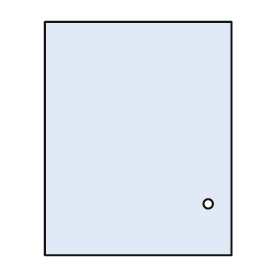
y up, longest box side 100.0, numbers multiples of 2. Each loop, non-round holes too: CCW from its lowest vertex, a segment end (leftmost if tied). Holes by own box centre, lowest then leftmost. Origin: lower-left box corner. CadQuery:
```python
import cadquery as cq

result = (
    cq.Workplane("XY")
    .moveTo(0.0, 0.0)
    .lineTo(80.0, 0.0)
    .lineTo(80.0, 100.0)
    .lineTo(0.0, 100.0)
    .close()
    .moveTo(70.0, 22.0)
    .circle(2.0)
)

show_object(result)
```